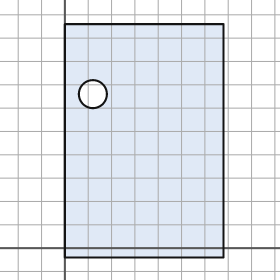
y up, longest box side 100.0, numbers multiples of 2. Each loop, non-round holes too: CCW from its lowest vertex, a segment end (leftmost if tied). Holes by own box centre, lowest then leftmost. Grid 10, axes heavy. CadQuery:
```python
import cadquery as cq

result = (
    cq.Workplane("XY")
    .moveTo(0.0, -4.0)
    .lineTo(68.0, -4.0)
    .lineTo(68.0, 96.0)
    .lineTo(0.0, 96.0)
    .close()
    .moveTo(12.0, 66.0)
    .circle(6.0)
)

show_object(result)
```